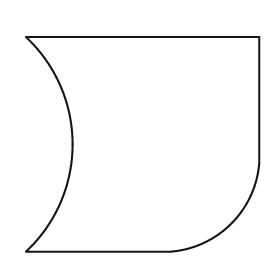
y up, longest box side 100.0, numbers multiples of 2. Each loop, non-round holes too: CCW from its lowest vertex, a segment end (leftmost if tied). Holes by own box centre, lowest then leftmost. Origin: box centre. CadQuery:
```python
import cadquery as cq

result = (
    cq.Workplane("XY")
    .moveTo(-50.0, -46.0)
    .lineTo(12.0, -46.0)
    .threePointArc((38.0, -34.0), (50.0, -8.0))
    .lineTo(50.0, 46.0)
    .lineTo(-50.0, 46.0)
    .threePointArc((-30.0, 0.0), (-50.0, -46.0))
    .close()
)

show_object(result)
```